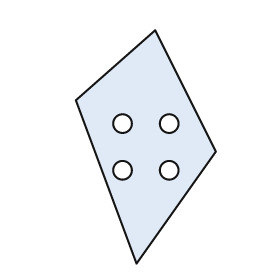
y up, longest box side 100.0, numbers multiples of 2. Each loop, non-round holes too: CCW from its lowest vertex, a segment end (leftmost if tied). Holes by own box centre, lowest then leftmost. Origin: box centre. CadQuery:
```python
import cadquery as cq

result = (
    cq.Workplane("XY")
    .moveTo(-4.0, -50.0)
    .lineTo(30.0, -2.0)
    .lineTo(4.0, 50.0)
    .lineTo(-30.0, 20.0)
    .close()
    .moveTo(-10.0, -10.0)
    .circle(4.0)
    .moveTo(10.0, -10.0)
    .circle(4.0)
    .moveTo(-10.0, 10.0)
    .circle(4.0)
    .moveTo(10.0, 10.0)
    .circle(4.0)
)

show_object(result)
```